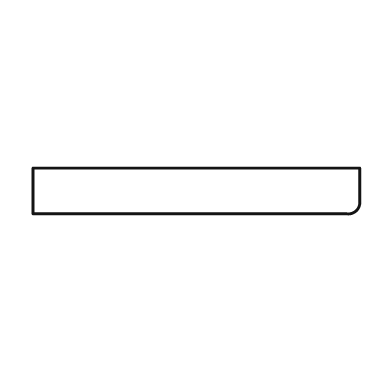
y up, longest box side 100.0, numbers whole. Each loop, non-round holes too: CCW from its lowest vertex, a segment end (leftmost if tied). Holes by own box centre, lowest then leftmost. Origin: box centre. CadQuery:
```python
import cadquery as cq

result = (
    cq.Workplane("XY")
    .moveTo(-50.0, -7.0)
    .lineTo(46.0, -7.0)
    .threePointArc((49.0, -6.0), (50.0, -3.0))
    .lineTo(50.0, 7.0)
    .lineTo(-50.0, 7.0)
    .close()
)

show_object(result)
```